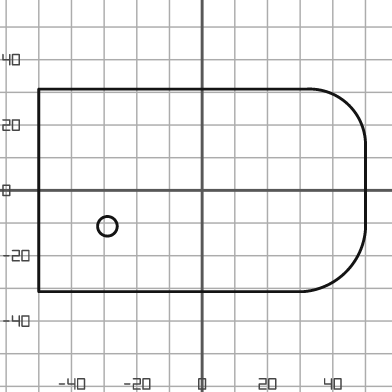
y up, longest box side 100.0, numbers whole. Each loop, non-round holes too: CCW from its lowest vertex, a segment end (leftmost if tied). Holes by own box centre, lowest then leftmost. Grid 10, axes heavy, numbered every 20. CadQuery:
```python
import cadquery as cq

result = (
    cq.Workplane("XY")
    .moveTo(-50.0, -31.0)
    .lineTo(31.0, -31.0)
    .threePointArc((44.0, -25.0), (50.0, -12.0))
    .lineTo(50.0, 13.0)
    .threePointArc((45.0, 26.0), (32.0, 31.0))
    .lineTo(-50.0, 31.0)
    .close()
    .moveTo(-29.0, -11.0)
    .circle(3.0)
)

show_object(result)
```